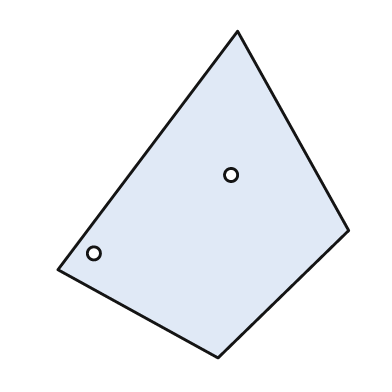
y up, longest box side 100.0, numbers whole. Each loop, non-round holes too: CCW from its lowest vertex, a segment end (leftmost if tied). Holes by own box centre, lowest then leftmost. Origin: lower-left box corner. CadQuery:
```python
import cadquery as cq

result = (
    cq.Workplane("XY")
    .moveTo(49.0, 0.0)
    .lineTo(89.0, 39.0)
    .lineTo(55.0, 100.0)
    .lineTo(0.0, 27.0)
    .close()
    .moveTo(11.0, 32.0)
    .circle(2.0)
    .moveTo(53.0, 56.0)
    .circle(2.0)
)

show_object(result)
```